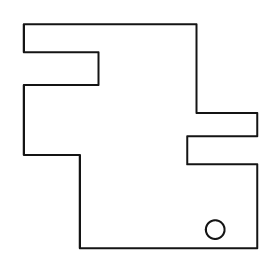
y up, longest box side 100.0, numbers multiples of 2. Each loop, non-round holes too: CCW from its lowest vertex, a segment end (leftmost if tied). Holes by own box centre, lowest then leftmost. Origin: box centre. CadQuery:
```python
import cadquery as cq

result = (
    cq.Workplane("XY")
    .moveTo(-26.0, -48.0)
    .lineTo(50.0, -48.0)
    .lineTo(50.0, -12.0)
    .lineTo(20.0, -12.0)
    .lineTo(20.0, 0.0)
    .lineTo(50.0, 0.0)
    .lineTo(50.0, 10.0)
    .lineTo(24.0, 10.0)
    .lineTo(24.0, 48.0)
    .lineTo(-50.0, 48.0)
    .lineTo(-50.0, 36.0)
    .lineTo(-18.0, 36.0)
    .lineTo(-18.0, 22.0)
    .lineTo(-50.0, 22.0)
    .lineTo(-50.0, -8.0)
    .lineTo(-26.0, -8.0)
    .close()
    .moveTo(32.0, -40.0)
    .circle(4.0)
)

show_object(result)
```